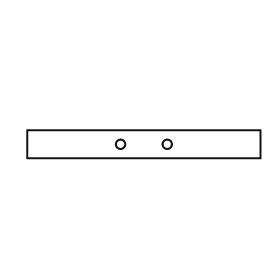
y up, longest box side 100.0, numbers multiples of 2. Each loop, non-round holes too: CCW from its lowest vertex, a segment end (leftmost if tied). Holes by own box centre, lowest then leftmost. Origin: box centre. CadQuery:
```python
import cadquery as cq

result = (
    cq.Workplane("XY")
    .moveTo(-50.0, -6.0)
    .lineTo(50.0, -6.0)
    .lineTo(50.0, 6.0)
    .lineTo(-50.0, 6.0)
    .close()
    .moveTo(-10.0, 0.0)
    .circle(2.0)
    .moveTo(10.0, 0.0)
    .circle(2.0)
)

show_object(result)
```